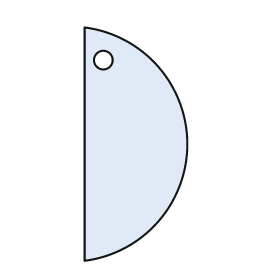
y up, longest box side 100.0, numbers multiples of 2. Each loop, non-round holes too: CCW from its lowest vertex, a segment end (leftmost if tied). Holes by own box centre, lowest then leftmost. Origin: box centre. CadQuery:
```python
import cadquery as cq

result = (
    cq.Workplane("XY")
    .moveTo(-22.0, -50.0)
    .threePointArc((22.0, 0.0), (-22.0, 50.0))
    .close()
    .moveTo(-14.0, 36.0)
    .circle(4.0)
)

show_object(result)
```